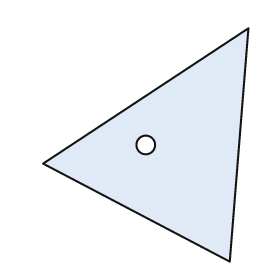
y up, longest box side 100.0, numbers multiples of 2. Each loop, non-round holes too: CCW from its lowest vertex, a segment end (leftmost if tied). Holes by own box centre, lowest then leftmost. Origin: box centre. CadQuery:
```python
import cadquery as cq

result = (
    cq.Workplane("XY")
    .moveTo(36.0, -50.0)
    .lineTo(44.0, 50.0)
    .lineTo(-44.0, -8.0)
    .close()
    .moveTo(0.0, 0.0)
    .circle(4.0)
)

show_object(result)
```